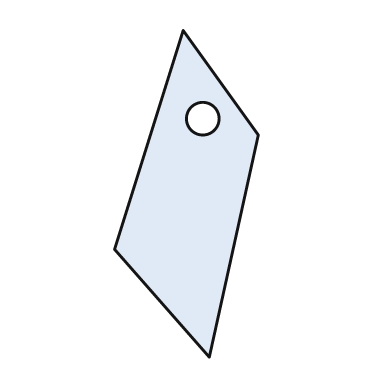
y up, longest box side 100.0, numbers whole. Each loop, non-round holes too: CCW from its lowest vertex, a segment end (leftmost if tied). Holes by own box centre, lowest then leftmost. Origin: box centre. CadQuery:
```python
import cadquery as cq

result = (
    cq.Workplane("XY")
    .moveTo(7.0, -50.0)
    .lineTo(22.0, 18.0)
    .lineTo(-1.0, 50.0)
    .lineTo(-22.0, -17.0)
    .close()
    .moveTo(5.0, 23.0)
    .circle(5.0)
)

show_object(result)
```